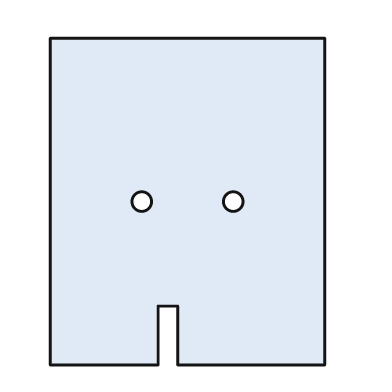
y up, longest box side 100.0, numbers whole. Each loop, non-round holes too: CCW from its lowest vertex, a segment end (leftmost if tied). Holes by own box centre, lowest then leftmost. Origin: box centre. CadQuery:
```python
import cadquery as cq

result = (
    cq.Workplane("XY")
    .moveTo(-42.0, -50.0)
    .lineTo(-9.0, -50.0)
    .lineTo(-9.0, -32.0)
    .lineTo(-3.0, -32.0)
    .lineTo(-3.0, -50.0)
    .lineTo(42.0, -50.0)
    .lineTo(42.0, 50.0)
    .lineTo(-42.0, 50.0)
    .close()
    .moveTo(-14.0, 0.0)
    .circle(3.0)
    .moveTo(14.0, 0.0)
    .circle(3.0)
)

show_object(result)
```